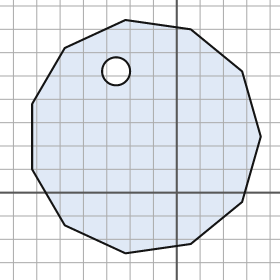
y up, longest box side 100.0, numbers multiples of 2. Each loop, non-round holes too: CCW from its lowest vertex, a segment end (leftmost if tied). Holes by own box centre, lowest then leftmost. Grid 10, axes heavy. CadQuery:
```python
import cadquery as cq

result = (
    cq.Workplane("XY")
    .moveTo(-22.0, -26.0)
    .lineTo(6.0, -22.0)
    .lineTo(28.0, -4.0)
    .lineTo(36.0, 24.0)
    .lineTo(28.0, 52.0)
    .lineTo(6.0, 70.0)
    .lineTo(-22.0, 74.0)
    .lineTo(-48.0, 62.0)
    .lineTo(-62.0, 38.0)
    .lineTo(-62.0, 10.0)
    .lineTo(-48.0, -14.0)
    .close()
    .moveTo(-26.0, 52.0)
    .circle(6.0)
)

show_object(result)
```